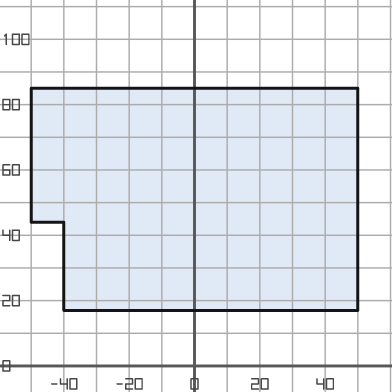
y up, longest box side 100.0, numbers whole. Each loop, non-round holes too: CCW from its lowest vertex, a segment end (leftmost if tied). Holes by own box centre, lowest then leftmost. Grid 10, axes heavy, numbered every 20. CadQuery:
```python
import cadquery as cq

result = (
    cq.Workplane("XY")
    .moveTo(-40.0, 17.0)
    .lineTo(50.0, 17.0)
    .lineTo(50.0, 85.0)
    .lineTo(-50.0, 85.0)
    .lineTo(-50.0, 44.0)
    .lineTo(-40.0, 44.0)
    .close()
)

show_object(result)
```